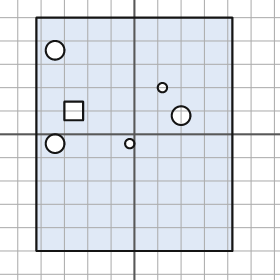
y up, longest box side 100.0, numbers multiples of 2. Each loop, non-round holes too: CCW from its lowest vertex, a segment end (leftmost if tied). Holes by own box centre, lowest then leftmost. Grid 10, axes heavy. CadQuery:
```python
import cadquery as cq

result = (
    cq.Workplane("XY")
    .moveTo(-42.0, -50.0)
    .lineTo(42.0, -50.0)
    .lineTo(42.0, 50.0)
    .lineTo(-42.0, 50.0)
    .close()
    .moveTo(-34.0, -4.0)
    .circle(4.0)
    .moveTo(-2.0, -4.0)
    .circle(2.0)
    .moveTo(20.0, 8.0)
    .circle(4.0)
    .moveTo(-30.0, 6.0)
    .lineTo(-22.0, 6.0)
    .lineTo(-22.0, 14.0)
    .lineTo(-30.0, 14.0)
    .close()
    .moveTo(12.0, 20.0)
    .circle(2.0)
    .moveTo(-34.0, 36.0)
    .circle(4.0)
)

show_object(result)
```